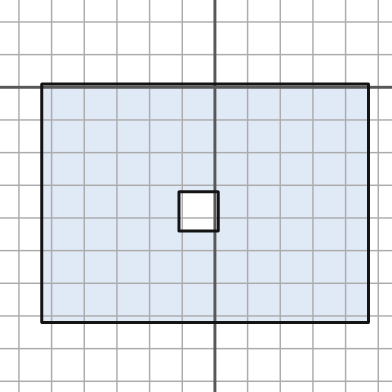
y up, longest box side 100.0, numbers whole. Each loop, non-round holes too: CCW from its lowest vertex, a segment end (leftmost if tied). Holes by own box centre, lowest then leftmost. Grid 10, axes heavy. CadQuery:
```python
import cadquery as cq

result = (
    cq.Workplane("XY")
    .moveTo(-53.0, -72.0)
    .lineTo(47.0, -72.0)
    .lineTo(47.0, 1.0)
    .lineTo(-53.0, 1.0)
    .close()
    .moveTo(-11.0, -44.0)
    .lineTo(1.0, -44.0)
    .lineTo(1.0, -32.0)
    .lineTo(-11.0, -32.0)
    .close()
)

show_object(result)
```